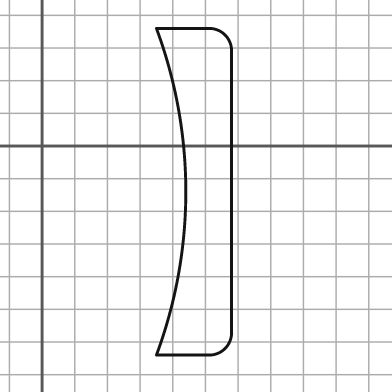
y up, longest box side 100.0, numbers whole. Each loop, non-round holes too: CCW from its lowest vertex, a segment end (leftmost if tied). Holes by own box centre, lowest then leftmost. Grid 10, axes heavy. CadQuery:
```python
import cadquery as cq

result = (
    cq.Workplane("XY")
    .moveTo(35.0, -64.0)
    .lineTo(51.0, -64.0)
    .threePointArc((56.0, -62.0), (58.0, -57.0))
    .lineTo(58.0, 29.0)
    .threePointArc((56.0, 34.0), (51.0, 36.0))
    .lineTo(35.0, 36.0)
    .threePointArc((44.0, -14.0), (35.0, -64.0))
    .close()
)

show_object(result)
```